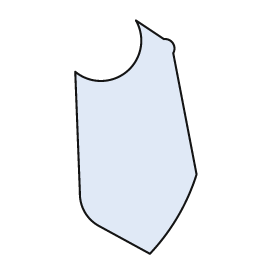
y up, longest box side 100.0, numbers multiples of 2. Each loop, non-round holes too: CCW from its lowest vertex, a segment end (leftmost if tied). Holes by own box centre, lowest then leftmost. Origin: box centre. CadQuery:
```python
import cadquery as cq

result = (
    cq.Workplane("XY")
    .moveTo(6.0, -50.0)
    .threePointArc((18.0, -34.0), (26.0, -16.0))
    .lineTo(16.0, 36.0)
    .threePointArc((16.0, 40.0), (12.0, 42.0))
    .lineTo(0.0, 50.0)
    .threePointArc((-4.0, 28.0), (-26.0, 28.0))
    .lineTo(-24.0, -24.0)
    .threePointArc((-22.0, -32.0), (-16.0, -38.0))
    .close()
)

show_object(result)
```